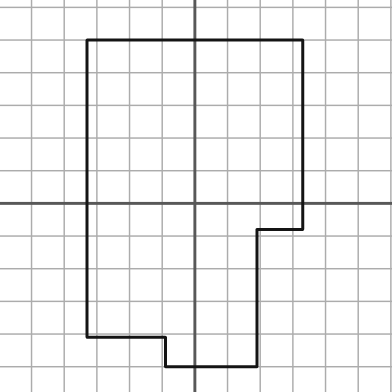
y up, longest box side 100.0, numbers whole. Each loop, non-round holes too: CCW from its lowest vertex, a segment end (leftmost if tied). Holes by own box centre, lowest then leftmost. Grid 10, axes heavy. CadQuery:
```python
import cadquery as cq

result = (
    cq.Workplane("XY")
    .moveTo(-9.0, -50.0)
    .lineTo(19.0, -50.0)
    .lineTo(19.0, -8.0)
    .lineTo(33.0, -8.0)
    .lineTo(33.0, 50.0)
    .lineTo(-33.0, 50.0)
    .lineTo(-33.0, -41.0)
    .lineTo(-9.0, -41.0)
    .close()
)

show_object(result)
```